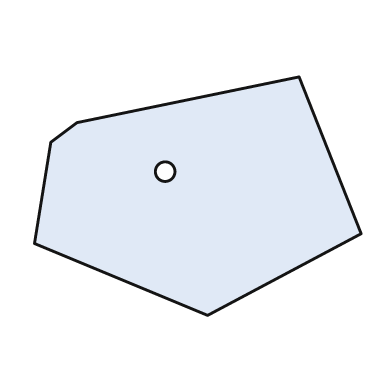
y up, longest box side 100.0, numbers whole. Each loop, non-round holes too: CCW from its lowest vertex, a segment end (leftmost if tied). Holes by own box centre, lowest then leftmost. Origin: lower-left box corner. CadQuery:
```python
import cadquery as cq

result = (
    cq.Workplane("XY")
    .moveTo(53.0, 0.0)
    .lineTo(100.0, 25.0)
    .lineTo(81.0, 73.0)
    .lineTo(13.0, 59.0)
    .lineTo(5.0, 53.0)
    .lineTo(0.0, 22.0)
    .close()
    .moveTo(40.0, 44.0)
    .circle(3.0)
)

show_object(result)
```